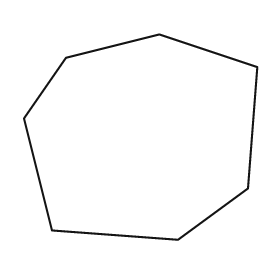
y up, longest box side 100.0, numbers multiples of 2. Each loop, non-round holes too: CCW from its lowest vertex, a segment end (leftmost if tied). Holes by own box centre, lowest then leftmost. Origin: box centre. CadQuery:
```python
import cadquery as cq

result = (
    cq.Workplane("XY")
    .moveTo(16.0, -44.0)
    .lineTo(46.0, -22.0)
    .lineTo(50.0, 30.0)
    .lineTo(8.0, 44.0)
    .lineTo(-32.0, 34.0)
    .lineTo(-50.0, 8.0)
    .lineTo(-38.0, -40.0)
    .close()
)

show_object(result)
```